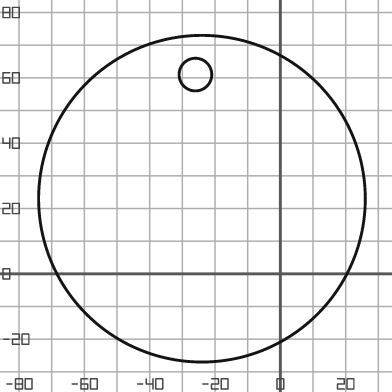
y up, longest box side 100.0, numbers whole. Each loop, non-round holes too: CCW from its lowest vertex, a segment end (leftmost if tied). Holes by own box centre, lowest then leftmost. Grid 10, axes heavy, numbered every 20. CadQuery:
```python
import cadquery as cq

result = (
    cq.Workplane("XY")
    .moveTo(-24.0, 23.0)
    .circle(50.0)
    .moveTo(-26.0, 61.0)
    .circle(5.0)
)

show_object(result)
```